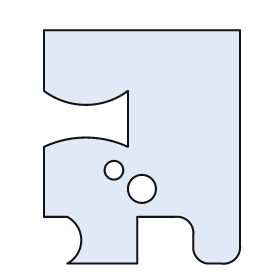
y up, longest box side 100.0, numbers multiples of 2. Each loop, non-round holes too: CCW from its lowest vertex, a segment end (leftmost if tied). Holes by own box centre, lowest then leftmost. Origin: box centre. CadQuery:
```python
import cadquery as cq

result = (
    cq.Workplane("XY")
    .moveTo(-32.0, -50.0)
    .lineTo(-2.0, -50.0)
    .lineTo(-2.0, -30.0)
    .lineTo(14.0, -30.0)
    .threePointArc((20.0, -32.0), (22.0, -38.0))
    .lineTo(22.0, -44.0)
    .threePointArc((24.0, -48.0), (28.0, -50.0))
    .lineTo(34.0, -50.0)
    .threePointArc((40.0, -48.0), (42.0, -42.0))
    .lineTo(42.0, 50.0)
    .lineTo(-42.0, 50.0)
    .lineTo(-42.0, 24.0)
    .threePointArc((-24.0, 18.0), (-6.0, 24.0))
    .lineTo(-6.0, 0.0)
    .threePointArc((-24.0, 4.0), (-42.0, 0.0))
    .lineTo(-42.0, -30.0)
    .lineTo(-32.0, -30.0)
    .threePointArc((-26.0, -40.0), (-32.0, -50.0))
    .close()
    .moveTo(0.0, -18.0)
    .circle(6.0)
    .moveTo(-12.0, -10.0)
    .circle(4.0)
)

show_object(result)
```